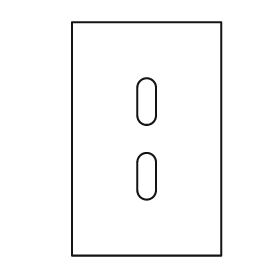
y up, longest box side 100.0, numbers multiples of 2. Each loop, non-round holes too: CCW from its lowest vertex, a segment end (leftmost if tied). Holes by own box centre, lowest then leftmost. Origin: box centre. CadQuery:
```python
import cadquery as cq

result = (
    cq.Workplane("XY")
    .moveTo(-32.0, -50.0)
    .lineTo(32.0, -50.0)
    .lineTo(32.0, 50.0)
    .lineTo(-32.0, 50.0)
    .close()
    .moveTo(-4.0, -22.0)
    .threePointArc((0.0, -26.0), (4.0, -22.0))
    .lineTo(4.0, -10.0)
    .threePointArc((0.0, -6.0), (-4.0, -10.0))
    .close()
    .moveTo(-4.0, 10.0)
    .threePointArc((0.0, 6.0), (4.0, 10.0))
    .lineTo(4.0, 22.0)
    .threePointArc((0.0, 26.0), (-4.0, 22.0))
    .close()
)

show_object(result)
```